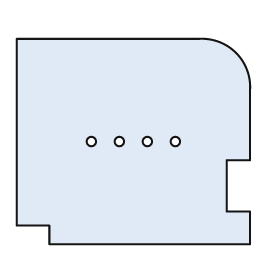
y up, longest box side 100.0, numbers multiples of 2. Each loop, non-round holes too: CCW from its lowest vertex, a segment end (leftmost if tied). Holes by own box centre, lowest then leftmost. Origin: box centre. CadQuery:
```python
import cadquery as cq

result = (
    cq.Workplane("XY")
    .moveTo(-36.0, -44.0)
    .lineTo(50.0, -44.0)
    .lineTo(50.0, -30.0)
    .lineTo(40.0, -30.0)
    .lineTo(40.0, -8.0)
    .lineTo(50.0, -8.0)
    .lineTo(50.0, 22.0)
    .threePointArc((44.0, 38.0), (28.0, 44.0))
    .lineTo(-50.0, 44.0)
    .lineTo(-50.0, -36.0)
    .lineTo(-36.0, -36.0)
    .close()
    .moveTo(-18.0, 0.0)
    .circle(2.0)
    .moveTo(-6.0, 0.0)
    .circle(2.0)
    .moveTo(6.0, 0.0)
    .circle(2.0)
    .moveTo(18.0, 0.0)
    .circle(2.0)
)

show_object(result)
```